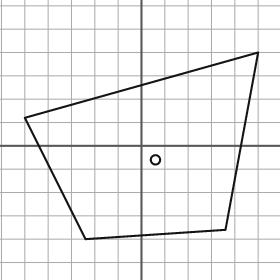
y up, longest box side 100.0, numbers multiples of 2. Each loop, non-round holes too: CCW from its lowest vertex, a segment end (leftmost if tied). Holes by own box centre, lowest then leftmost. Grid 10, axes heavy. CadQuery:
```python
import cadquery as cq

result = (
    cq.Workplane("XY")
    .moveTo(-24.0, -40.0)
    .lineTo(36.0, -36.0)
    .lineTo(50.0, 40.0)
    .lineTo(-50.0, 12.0)
    .close()
    .moveTo(6.0, -6.0)
    .circle(2.0)
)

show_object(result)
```